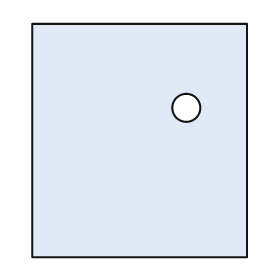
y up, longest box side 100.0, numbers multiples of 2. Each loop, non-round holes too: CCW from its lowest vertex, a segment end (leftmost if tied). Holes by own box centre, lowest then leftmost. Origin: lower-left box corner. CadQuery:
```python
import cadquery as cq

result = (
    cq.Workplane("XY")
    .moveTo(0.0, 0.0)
    .lineTo(92.0, 0.0)
    .lineTo(92.0, 100.0)
    .lineTo(0.0, 100.0)
    .close()
    .moveTo(66.0, 64.0)
    .circle(6.0)
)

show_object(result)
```